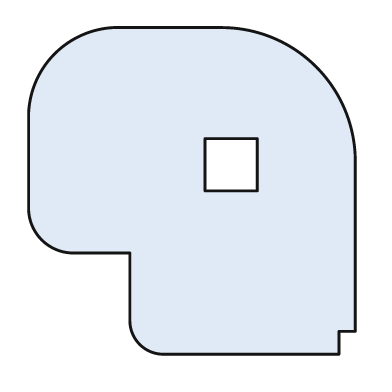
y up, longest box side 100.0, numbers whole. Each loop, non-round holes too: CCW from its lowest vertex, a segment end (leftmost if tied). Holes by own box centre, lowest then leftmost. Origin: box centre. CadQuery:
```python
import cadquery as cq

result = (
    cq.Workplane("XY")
    .moveTo(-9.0, -50.0)
    .lineTo(45.0, -50.0)
    .lineTo(45.0, -43.0)
    .lineTo(50.0, -43.0)
    .lineTo(50.0, 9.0)
    .threePointArc((38.0, 38.0), (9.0, 50.0))
    .lineTo(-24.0, 50.0)
    .threePointArc((-42.0, 42.0), (-50.0, 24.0))
    .lineTo(-50.0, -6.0)
    .threePointArc((-46.0, -15.0), (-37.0, -19.0))
    .lineTo(-19.0, -19.0)
    .lineTo(-19.0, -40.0)
    .threePointArc((-16.0, -47.0), (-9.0, -50.0))
    .close()
    .moveTo(4.0, 0.0)
    .lineTo(20.0, 0.0)
    .lineTo(20.0, 16.0)
    .lineTo(4.0, 16.0)
    .close()
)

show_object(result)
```